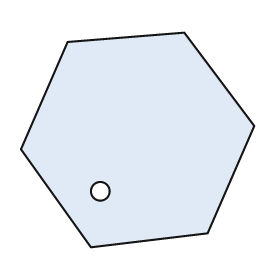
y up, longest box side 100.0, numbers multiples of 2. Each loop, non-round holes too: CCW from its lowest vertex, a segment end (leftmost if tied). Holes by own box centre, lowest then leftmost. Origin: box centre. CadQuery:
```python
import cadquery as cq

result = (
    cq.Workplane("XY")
    .moveTo(-20.0, -46.0)
    .lineTo(30.0, -40.0)
    .lineTo(50.0, 6.0)
    .lineTo(20.0, 46.0)
    .lineTo(-30.0, 42.0)
    .lineTo(-50.0, -4.0)
    .close()
    .moveTo(-16.0, -22.0)
    .circle(4.0)
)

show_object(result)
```